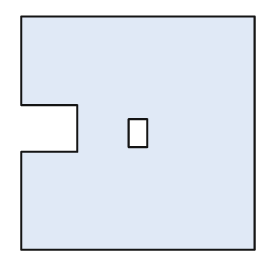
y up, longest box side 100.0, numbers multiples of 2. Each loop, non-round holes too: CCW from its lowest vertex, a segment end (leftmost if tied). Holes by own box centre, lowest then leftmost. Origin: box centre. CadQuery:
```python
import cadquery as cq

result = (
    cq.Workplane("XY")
    .moveTo(-50.0, -50.0)
    .lineTo(50.0, -50.0)
    .lineTo(50.0, 50.0)
    .lineTo(-50.0, 50.0)
    .lineTo(-50.0, 12.0)
    .lineTo(-26.0, 12.0)
    .lineTo(-26.0, -8.0)
    .lineTo(-50.0, -8.0)
    .close()
    .moveTo(-4.0, -6.0)
    .lineTo(4.0, -6.0)
    .lineTo(4.0, 6.0)
    .lineTo(-4.0, 6.0)
    .close()
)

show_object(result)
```